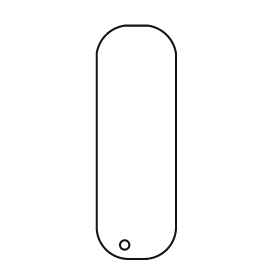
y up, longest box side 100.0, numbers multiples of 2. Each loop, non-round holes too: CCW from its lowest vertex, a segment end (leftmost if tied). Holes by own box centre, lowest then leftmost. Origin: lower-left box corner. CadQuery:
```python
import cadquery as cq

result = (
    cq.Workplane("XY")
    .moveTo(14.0, 0.0)
    .lineTo(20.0, 0.0)
    .threePointArc((30.0, 4.0), (34.0, 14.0))
    .lineTo(34.0, 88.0)
    .threePointArc((30.0, 96.0), (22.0, 100.0))
    .lineTo(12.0, 100.0)
    .threePointArc((4.0, 96.0), (0.0, 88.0))
    .lineTo(0.0, 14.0)
    .threePointArc((4.0, 4.0), (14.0, 0.0))
    .close()
    .moveTo(12.0, 6.0)
    .circle(2.0)
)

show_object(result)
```